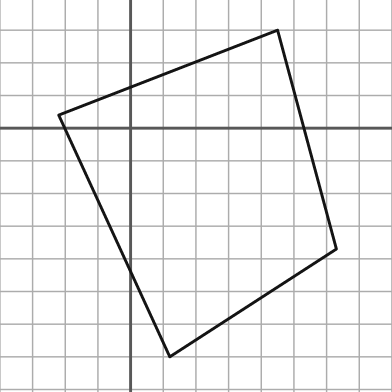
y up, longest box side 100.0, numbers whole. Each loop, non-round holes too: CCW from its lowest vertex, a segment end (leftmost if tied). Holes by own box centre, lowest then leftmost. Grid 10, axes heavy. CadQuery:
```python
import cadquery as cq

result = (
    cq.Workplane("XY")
    .moveTo(12.0, -70.0)
    .lineTo(63.0, -37.0)
    .lineTo(45.0, 30.0)
    .lineTo(-22.0, 4.0)
    .close()
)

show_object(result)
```